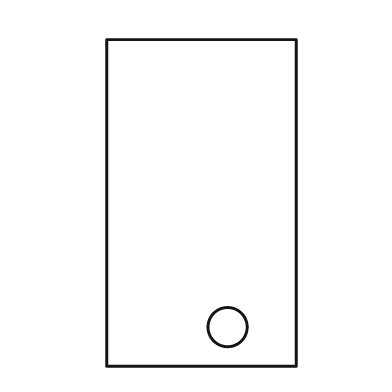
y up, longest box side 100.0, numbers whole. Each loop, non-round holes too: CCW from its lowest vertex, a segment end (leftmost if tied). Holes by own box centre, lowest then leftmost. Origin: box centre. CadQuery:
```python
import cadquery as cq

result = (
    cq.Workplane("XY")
    .moveTo(-29.0, -50.0)
    .lineTo(29.0, -50.0)
    .lineTo(29.0, 50.0)
    .lineTo(-29.0, 50.0)
    .close()
    .moveTo(8.0, -38.0)
    .circle(6.0)
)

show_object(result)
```